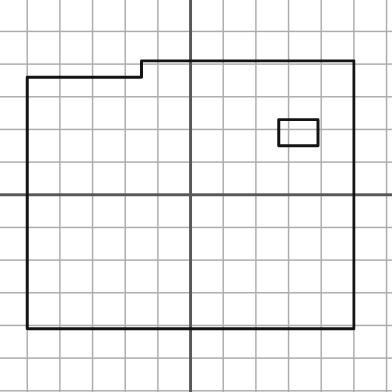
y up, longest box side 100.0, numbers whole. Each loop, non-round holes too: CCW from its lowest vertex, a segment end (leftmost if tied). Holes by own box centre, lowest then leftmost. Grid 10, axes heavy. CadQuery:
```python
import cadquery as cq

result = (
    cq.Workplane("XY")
    .moveTo(-50.0, -41.0)
    .lineTo(50.0, -41.0)
    .lineTo(50.0, 41.0)
    .lineTo(-15.0, 41.0)
    .lineTo(-15.0, 36.0)
    .lineTo(-50.0, 36.0)
    .close()
    .moveTo(27.0, 15.0)
    .lineTo(39.0, 15.0)
    .lineTo(39.0, 23.0)
    .lineTo(27.0, 23.0)
    .close()
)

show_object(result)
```